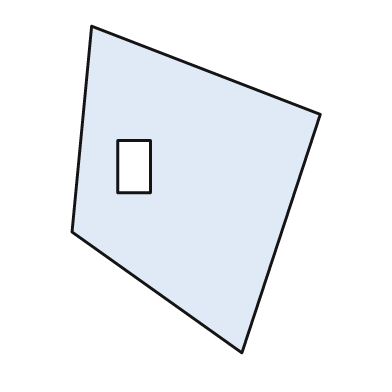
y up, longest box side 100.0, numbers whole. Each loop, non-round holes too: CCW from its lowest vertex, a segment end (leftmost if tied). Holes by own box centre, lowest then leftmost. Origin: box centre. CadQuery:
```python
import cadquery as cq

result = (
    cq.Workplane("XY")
    .moveTo(14.0, -50.0)
    .lineTo(38.0, 23.0)
    .lineTo(-32.0, 50.0)
    .lineTo(-38.0, -13.0)
    .close()
    .moveTo(-24.0, -1.0)
    .lineTo(-14.0, -1.0)
    .lineTo(-14.0, 15.0)
    .lineTo(-24.0, 15.0)
    .close()
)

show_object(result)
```